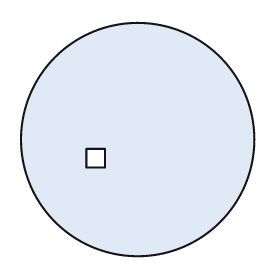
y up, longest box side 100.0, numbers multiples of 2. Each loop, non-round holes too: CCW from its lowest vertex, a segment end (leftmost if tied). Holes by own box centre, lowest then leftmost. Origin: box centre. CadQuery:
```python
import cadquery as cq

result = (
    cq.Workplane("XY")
    .moveTo(0.0, 0.0)
    .circle(50.0)
    .moveTo(-22.0, -12.0)
    .lineTo(-14.0, -12.0)
    .lineTo(-14.0, -4.0)
    .lineTo(-22.0, -4.0)
    .close()
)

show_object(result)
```